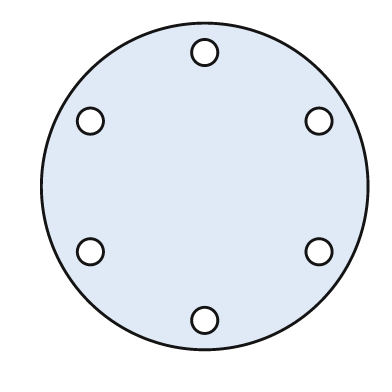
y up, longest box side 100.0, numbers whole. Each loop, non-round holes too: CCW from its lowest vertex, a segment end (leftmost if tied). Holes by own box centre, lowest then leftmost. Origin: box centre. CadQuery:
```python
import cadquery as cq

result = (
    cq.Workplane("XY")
    .moveTo(0.0, 0.0)
    .circle(50.0)
    .moveTo(0.0, -41.0)
    .circle(4.0)
    .moveTo(-35.0, -20.0)
    .circle(4.0)
    .moveTo(35.0, -20.0)
    .circle(4.0)
    .moveTo(-35.0, 20.0)
    .circle(4.0)
    .moveTo(35.0, 20.0)
    .circle(4.0)
    .moveTo(0.0, 41.0)
    .circle(4.0)
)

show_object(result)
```